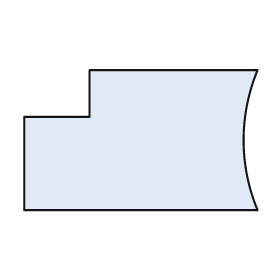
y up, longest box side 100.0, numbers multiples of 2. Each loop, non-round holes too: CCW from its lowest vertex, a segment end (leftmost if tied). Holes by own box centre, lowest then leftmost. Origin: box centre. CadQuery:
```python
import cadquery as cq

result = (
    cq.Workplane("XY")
    .moveTo(-50.0, -30.0)
    .lineTo(50.0, -30.0)
    .threePointArc((44.0, 0.0), (50.0, 30.0))
    .lineTo(-22.0, 30.0)
    .lineTo(-22.0, 10.0)
    .lineTo(-50.0, 10.0)
    .close()
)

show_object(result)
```